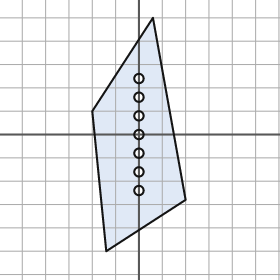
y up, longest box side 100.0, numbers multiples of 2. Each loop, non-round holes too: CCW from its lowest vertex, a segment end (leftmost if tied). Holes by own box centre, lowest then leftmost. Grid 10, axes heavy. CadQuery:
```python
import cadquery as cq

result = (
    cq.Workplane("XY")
    .moveTo(-14.0, -50.0)
    .lineTo(20.0, -28.0)
    .lineTo(6.0, 50.0)
    .lineTo(-20.0, 10.0)
    .close()
    .moveTo(0.0, -24.0)
    .circle(2.0)
    .moveTo(0.0, -16.0)
    .circle(2.0)
    .moveTo(0.0, -8.0)
    .circle(2.0)
    .moveTo(0.0, 0.0)
    .circle(2.0)
    .moveTo(0.0, 8.0)
    .circle(2.0)
    .moveTo(0.0, 16.0)
    .circle(2.0)
    .moveTo(0.0, 24.0)
    .circle(2.0)
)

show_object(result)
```